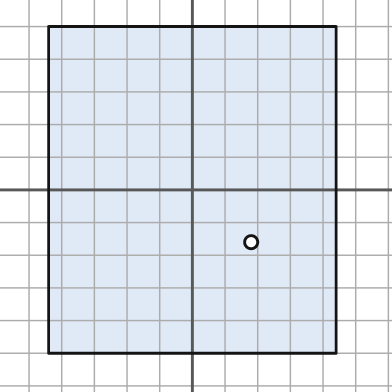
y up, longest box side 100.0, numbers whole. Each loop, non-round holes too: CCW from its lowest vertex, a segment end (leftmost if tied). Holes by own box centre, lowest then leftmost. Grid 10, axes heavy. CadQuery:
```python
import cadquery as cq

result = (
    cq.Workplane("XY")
    .moveTo(-44.0, -50.0)
    .lineTo(44.0, -50.0)
    .lineTo(44.0, 50.0)
    .lineTo(-44.0, 50.0)
    .close()
    .moveTo(18.0, -16.0)
    .circle(2.0)
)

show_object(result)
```